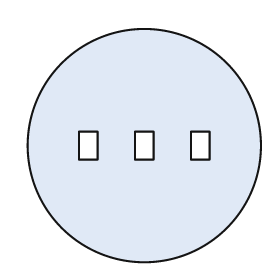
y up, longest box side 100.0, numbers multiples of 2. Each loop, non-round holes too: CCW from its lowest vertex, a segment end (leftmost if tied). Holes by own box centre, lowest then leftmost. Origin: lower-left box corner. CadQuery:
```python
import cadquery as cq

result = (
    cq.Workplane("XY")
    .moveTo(50.0, 50.0)
    .circle(50.0)
    .moveTo(22.0, 44.0)
    .lineTo(30.0, 44.0)
    .lineTo(30.0, 56.0)
    .lineTo(22.0, 56.0)
    .close()
    .moveTo(46.0, 44.0)
    .lineTo(54.0, 44.0)
    .lineTo(54.0, 56.0)
    .lineTo(46.0, 56.0)
    .close()
    .moveTo(70.0, 44.0)
    .lineTo(78.0, 44.0)
    .lineTo(78.0, 56.0)
    .lineTo(70.0, 56.0)
    .close()
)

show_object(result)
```